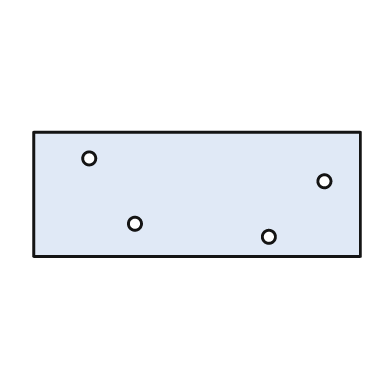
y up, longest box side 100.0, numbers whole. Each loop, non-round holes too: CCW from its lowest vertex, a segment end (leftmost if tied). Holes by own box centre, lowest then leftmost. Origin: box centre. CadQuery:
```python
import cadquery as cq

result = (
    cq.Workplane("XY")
    .moveTo(-50.0, -19.0)
    .lineTo(50.0, -19.0)
    .lineTo(50.0, 19.0)
    .lineTo(-50.0, 19.0)
    .close()
    .moveTo(22.0, -13.0)
    .circle(2.0)
    .moveTo(-19.0, -9.0)
    .circle(2.0)
    .moveTo(39.0, 4.0)
    .circle(2.0)
    .moveTo(-33.0, 11.0)
    .circle(2.0)
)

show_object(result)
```